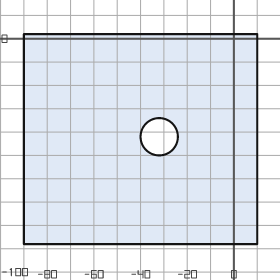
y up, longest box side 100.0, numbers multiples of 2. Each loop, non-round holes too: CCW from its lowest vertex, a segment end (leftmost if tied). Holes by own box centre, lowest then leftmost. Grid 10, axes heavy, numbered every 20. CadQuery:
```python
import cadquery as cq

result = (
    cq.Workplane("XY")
    .moveTo(-90.0, -88.0)
    .lineTo(10.0, -88.0)
    .lineTo(10.0, 2.0)
    .lineTo(-90.0, 2.0)
    .close()
    .moveTo(-32.0, -42.0)
    .circle(8.0)
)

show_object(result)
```